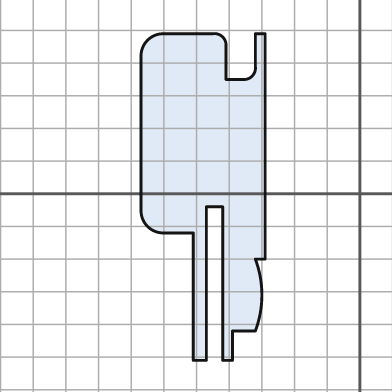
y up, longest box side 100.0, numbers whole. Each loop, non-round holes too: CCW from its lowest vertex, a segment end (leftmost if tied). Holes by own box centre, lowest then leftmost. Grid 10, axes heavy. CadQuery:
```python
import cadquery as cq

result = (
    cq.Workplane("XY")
    .moveTo(-51.0, -51.0)
    .lineTo(-47.0, -51.0)
    .lineTo(-47.0, -4.0)
    .lineTo(-42.0, -4.0)
    .lineTo(-42.0, -51.0)
    .lineTo(-39.0, -51.0)
    .lineTo(-39.0, -42.0)
    .lineTo(-32.0, -42.0)
    .threePointArc((-30.0, -31.0), (-32.0, -20.0))
    .lineTo(-29.0, -20.0)
    .lineTo(-29.0, 49.0)
    .lineTo(-32.0, 49.0)
    .lineTo(-32.0, 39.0)
    .threePointArc((-33.0, 36.0), (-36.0, 35.0))
    .lineTo(-41.0, 35.0)
    .lineTo(-41.0, 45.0)
    .threePointArc((-42.0, 48.0), (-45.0, 49.0))
    .lineTo(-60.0, 49.0)
    .threePointArc((-65.0, 47.0), (-67.0, 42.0))
    .lineTo(-67.0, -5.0)
    .threePointArc((-65.0, -10.0), (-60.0, -12.0))
    .lineTo(-51.0, -12.0)
    .close()
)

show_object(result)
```